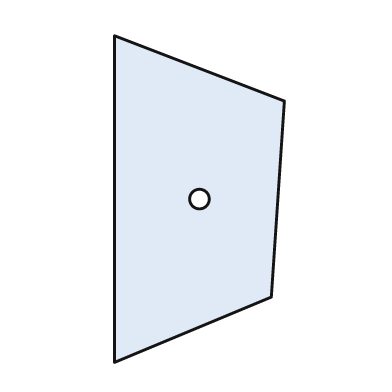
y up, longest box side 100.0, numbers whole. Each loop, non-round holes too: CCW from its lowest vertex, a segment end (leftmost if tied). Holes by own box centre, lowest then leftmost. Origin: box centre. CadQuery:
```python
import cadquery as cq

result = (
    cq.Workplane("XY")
    .moveTo(-26.0, -50.0)
    .lineTo(22.0, -30.0)
    .lineTo(26.0, 30.0)
    .lineTo(-26.0, 50.0)
    .close()
    .moveTo(0.0, 0.0)
    .circle(3.0)
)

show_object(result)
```